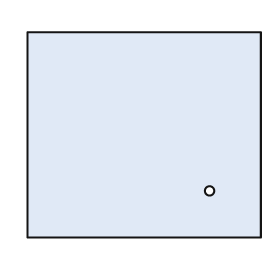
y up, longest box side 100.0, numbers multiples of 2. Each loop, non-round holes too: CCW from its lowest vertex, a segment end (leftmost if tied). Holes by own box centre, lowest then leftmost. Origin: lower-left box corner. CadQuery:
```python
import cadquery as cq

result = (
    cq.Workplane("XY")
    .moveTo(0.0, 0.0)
    .lineTo(100.0, 0.0)
    .lineTo(100.0, 88.0)
    .lineTo(0.0, 88.0)
    .close()
    .moveTo(78.0, 20.0)
    .circle(2.0)
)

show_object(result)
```